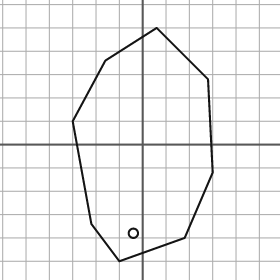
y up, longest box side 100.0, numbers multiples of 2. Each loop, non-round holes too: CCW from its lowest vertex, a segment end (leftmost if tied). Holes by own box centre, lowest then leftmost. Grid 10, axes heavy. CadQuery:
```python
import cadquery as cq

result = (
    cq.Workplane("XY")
    .moveTo(-10.0, -50.0)
    .lineTo(18.0, -40.0)
    .lineTo(30.0, -12.0)
    .lineTo(28.0, 28.0)
    .lineTo(6.0, 50.0)
    .lineTo(-16.0, 36.0)
    .lineTo(-30.0, 10.0)
    .lineTo(-22.0, -34.0)
    .close()
    .moveTo(-4.0, -38.0)
    .circle(2.0)
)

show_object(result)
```